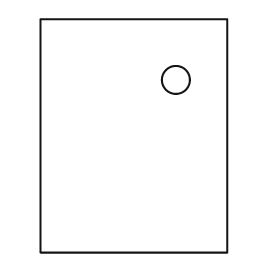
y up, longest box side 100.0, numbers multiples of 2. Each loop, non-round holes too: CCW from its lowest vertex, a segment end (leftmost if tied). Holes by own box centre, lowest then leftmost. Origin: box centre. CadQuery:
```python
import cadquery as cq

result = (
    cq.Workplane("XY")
    .moveTo(-40.0, -50.0)
    .lineTo(40.0, -50.0)
    .lineTo(40.0, 50.0)
    .lineTo(-40.0, 50.0)
    .close()
    .moveTo(18.0, 24.0)
    .circle(6.0)
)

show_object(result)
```